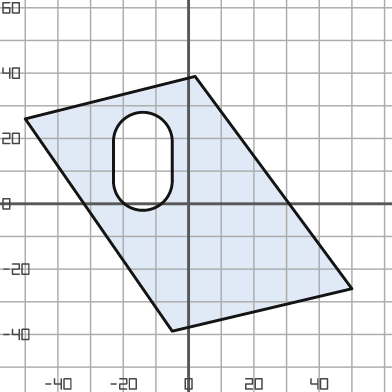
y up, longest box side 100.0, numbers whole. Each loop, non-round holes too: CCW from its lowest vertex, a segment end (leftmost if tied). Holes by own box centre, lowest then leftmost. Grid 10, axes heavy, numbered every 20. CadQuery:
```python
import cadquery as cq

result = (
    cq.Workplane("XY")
    .moveTo(-5.0, -39.0)
    .lineTo(50.0, -26.0)
    .lineTo(2.0, 39.0)
    .lineTo(-50.0, 26.0)
    .close()
    .moveTo(-23.0, 7.0)
    .threePointArc((-14.0, -2.0), (-5.0, 7.0))
    .lineTo(-5.0, 19.0)
    .threePointArc((-14.0, 28.0), (-23.0, 19.0))
    .close()
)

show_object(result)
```